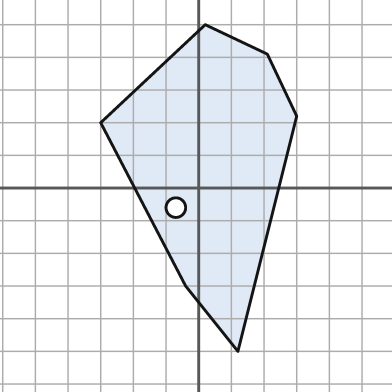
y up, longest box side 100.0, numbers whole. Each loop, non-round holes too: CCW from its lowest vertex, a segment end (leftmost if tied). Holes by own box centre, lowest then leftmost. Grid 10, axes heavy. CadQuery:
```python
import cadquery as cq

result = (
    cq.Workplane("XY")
    .moveTo(12.0, -50.0)
    .lineTo(30.0, 22.0)
    .lineTo(21.0, 41.0)
    .lineTo(2.0, 50.0)
    .lineTo(-30.0, 20.0)
    .lineTo(-4.0, -30.0)
    .close()
    .moveTo(-7.0, -6.0)
    .circle(3.0)
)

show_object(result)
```